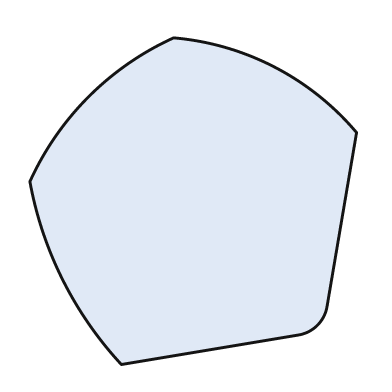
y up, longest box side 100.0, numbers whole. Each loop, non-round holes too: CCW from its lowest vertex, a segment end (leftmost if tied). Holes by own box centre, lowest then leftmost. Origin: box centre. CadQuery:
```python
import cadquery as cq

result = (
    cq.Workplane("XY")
    .moveTo(-22.0, -50.0)
    .lineTo(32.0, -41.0)
    .threePointArc((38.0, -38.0), (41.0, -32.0))
    .lineTo(50.0, 21.0)
    .threePointArc((25.0, 41.0), (-6.0, 50.0))
    .threePointArc((-32.0, 32.0), (-50.0, 6.0))
    .threePointArc((-40.0, -24.0), (-22.0, -50.0))
    .close()
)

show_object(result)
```